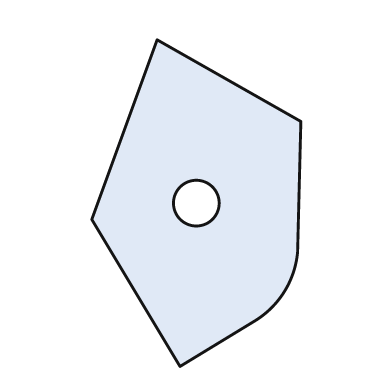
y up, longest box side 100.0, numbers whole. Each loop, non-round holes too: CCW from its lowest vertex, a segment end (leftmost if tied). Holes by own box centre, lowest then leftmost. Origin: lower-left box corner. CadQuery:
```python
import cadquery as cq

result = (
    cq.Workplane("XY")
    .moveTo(27.0, 0.0)
    .lineTo(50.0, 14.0)
    .threePointArc((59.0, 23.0), (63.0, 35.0))
    .lineTo(64.0, 75.0)
    .lineTo(20.0, 100.0)
    .lineTo(0.0, 45.0)
    .close()
    .moveTo(32.0, 50.0)
    .circle(7.0)
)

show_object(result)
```